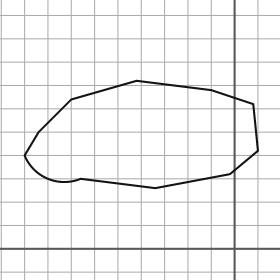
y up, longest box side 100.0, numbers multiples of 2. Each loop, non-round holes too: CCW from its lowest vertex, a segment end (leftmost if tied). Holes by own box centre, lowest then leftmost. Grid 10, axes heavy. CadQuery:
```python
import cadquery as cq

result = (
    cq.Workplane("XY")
    .moveTo(-34.0, 26.0)
    .lineTo(-2.0, 32.0)
    .lineTo(10.0, 42.0)
    .lineTo(8.0, 62.0)
    .lineTo(-10.0, 68.0)
    .lineTo(-42.0, 72.0)
    .lineTo(-70.0, 64.0)
    .lineTo(-84.0, 50.0)
    .lineTo(-90.0, 40.0)
    .threePointArc((-80.0, 30.0), (-66.0, 30.0))
    .close()
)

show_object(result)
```